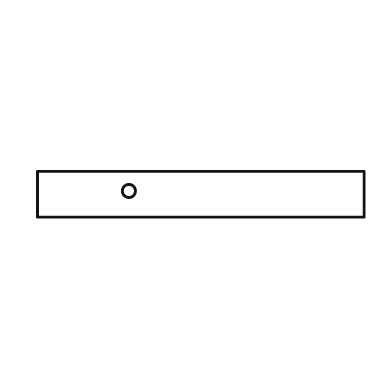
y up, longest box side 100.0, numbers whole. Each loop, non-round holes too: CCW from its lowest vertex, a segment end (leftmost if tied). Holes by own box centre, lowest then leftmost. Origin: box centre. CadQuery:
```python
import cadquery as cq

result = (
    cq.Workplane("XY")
    .moveTo(-50.0, -7.0)
    .lineTo(50.0, -7.0)
    .lineTo(50.0, 7.0)
    .lineTo(-50.0, 7.0)
    .close()
    .moveTo(-22.0, 1.0)
    .circle(2.0)
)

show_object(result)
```